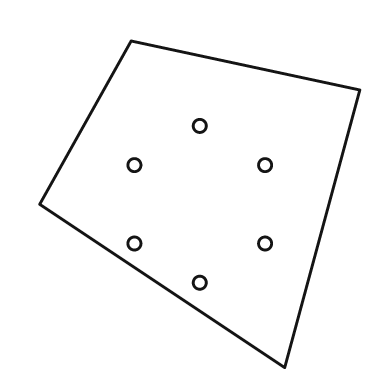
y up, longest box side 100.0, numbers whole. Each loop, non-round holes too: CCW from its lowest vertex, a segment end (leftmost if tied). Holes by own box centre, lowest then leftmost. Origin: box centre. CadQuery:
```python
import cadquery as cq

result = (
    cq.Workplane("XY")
    .moveTo(26.0, -50.0)
    .lineTo(49.0, 35.0)
    .lineTo(-21.0, 50.0)
    .lineTo(-49.0, 0.0)
    .close()
    .moveTo(0.0, -24.0)
    .circle(2.0)
    .moveTo(-20.0, -12.0)
    .circle(2.0)
    .moveTo(20.0, -12.0)
    .circle(2.0)
    .moveTo(-20.0, 12.0)
    .circle(2.0)
    .moveTo(20.0, 12.0)
    .circle(2.0)
    .moveTo(0.0, 24.0)
    .circle(2.0)
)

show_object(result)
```